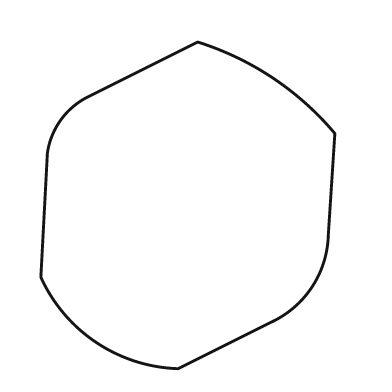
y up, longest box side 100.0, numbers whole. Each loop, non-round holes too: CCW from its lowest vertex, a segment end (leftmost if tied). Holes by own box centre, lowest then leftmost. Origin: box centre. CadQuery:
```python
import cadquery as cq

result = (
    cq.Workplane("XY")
    .moveTo(-3.0, -50.0)
    .lineTo(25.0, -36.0)
    .threePointArc((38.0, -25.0), (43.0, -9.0))
    .lineTo(45.0, 22.0)
    .threePointArc((26.0, 39.0), (3.0, 50.0))
    .lineTo(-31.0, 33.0)
    .threePointArc((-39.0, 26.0), (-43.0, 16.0))
    .lineTo(-45.0, -22.0)
    .threePointArc((-28.0, -42.0), (-3.0, -50.0))
    .close()
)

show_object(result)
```